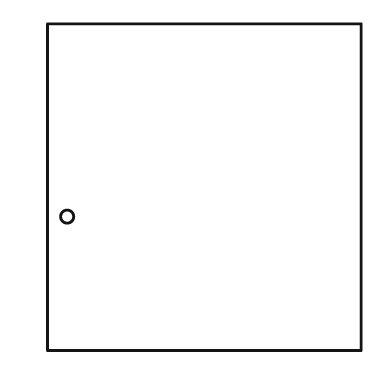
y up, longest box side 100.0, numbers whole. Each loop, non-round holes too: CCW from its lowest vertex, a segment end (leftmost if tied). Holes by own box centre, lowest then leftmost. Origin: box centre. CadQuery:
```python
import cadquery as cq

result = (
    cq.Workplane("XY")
    .moveTo(-48.0, -50.0)
    .lineTo(48.0, -50.0)
    .lineTo(48.0, 50.0)
    .lineTo(-48.0, 50.0)
    .close()
    .moveTo(-42.0, -9.0)
    .circle(2.0)
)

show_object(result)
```